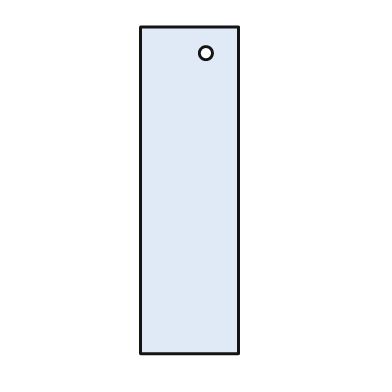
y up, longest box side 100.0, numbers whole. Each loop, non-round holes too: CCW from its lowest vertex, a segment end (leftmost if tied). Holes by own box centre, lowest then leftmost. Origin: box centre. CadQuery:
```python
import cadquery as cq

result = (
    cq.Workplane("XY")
    .moveTo(-15.0, -50.0)
    .lineTo(15.0, -50.0)
    .lineTo(15.0, 50.0)
    .lineTo(-15.0, 50.0)
    .close()
    .moveTo(5.0, 42.0)
    .circle(2.0)
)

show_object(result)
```